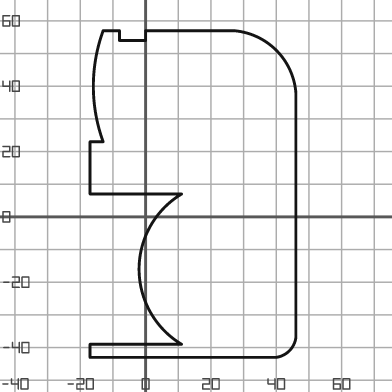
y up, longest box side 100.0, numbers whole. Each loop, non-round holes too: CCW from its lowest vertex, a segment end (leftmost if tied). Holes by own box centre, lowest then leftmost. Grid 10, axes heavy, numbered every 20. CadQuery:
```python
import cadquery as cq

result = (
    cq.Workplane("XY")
    .moveTo(-17.0, -43.0)
    .lineTo(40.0, -43.0)
    .threePointArc((44.0, -41.0), (46.0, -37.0))
    .lineTo(46.0, 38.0)
    .threePointArc((40.0, 51.0), (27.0, 57.0))
    .lineTo(0.0, 57.0)
    .lineTo(0.0, 54.0)
    .lineTo(-8.0, 54.0)
    .lineTo(-8.0, 57.0)
    .lineTo(-13.0, 57.0)
    .threePointArc((-16.0, 40.0), (-13.0, 23.0))
    .lineTo(-17.0, 23.0)
    .lineTo(-17.0, 7.0)
    .lineTo(11.0, 7.0)
    .threePointArc((-2.0, -16.0), (11.0, -39.0))
    .lineTo(-17.0, -39.0)
    .close()
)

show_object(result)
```